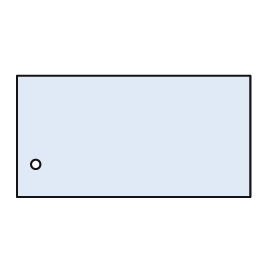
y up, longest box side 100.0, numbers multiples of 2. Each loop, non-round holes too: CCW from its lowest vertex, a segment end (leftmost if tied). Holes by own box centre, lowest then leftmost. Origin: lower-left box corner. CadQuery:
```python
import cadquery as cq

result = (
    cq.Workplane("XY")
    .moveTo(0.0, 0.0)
    .lineTo(100.0, 0.0)
    .lineTo(100.0, 52.0)
    .lineTo(0.0, 52.0)
    .close()
    .moveTo(8.0, 14.0)
    .circle(2.0)
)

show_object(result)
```